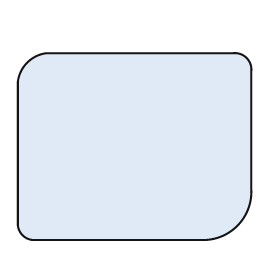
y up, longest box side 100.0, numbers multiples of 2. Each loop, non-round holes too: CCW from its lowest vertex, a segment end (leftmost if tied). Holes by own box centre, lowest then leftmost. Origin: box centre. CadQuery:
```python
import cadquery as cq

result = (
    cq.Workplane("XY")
    .moveTo(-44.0, -40.0)
    .lineTo(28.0, -40.0)
    .threePointArc((44.0, -34.0), (50.0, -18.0))
    .lineTo(50.0, 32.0)
    .threePointArc((48.0, 38.0), (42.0, 40.0))
    .lineTo(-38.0, 40.0)
    .threePointArc((-46.0, 36.0), (-50.0, 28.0))
    .lineTo(-50.0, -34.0)
    .threePointArc((-48.0, -38.0), (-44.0, -40.0))
    .close()
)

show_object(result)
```